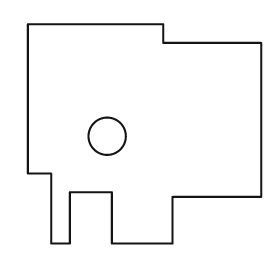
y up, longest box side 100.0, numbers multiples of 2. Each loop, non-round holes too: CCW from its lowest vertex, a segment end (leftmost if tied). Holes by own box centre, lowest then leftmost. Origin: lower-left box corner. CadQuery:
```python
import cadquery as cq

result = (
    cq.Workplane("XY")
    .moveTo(10.0, 0.0)
    .lineTo(18.0, 0.0)
    .lineTo(18.0, 22.0)
    .lineTo(36.0, 22.0)
    .lineTo(36.0, 0.0)
    .lineTo(62.0, 0.0)
    .lineTo(62.0, 20.0)
    .lineTo(100.0, 20.0)
    .lineTo(100.0, 86.0)
    .lineTo(58.0, 86.0)
    .lineTo(58.0, 94.0)
    .lineTo(0.0, 94.0)
    .lineTo(0.0, 30.0)
    .lineTo(10.0, 30.0)
    .close()
    .moveTo(34.0, 46.0)
    .circle(8.0)
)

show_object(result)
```